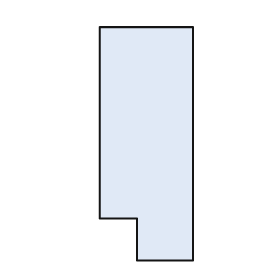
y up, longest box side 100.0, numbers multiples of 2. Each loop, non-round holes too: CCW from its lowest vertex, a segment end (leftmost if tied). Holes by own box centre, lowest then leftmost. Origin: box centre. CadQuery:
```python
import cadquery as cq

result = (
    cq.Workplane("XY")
    .moveTo(-4.0, -50.0)
    .lineTo(20.0, -50.0)
    .lineTo(20.0, 50.0)
    .lineTo(-20.0, 50.0)
    .lineTo(-20.0, -32.0)
    .lineTo(-4.0, -32.0)
    .close()
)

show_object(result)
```